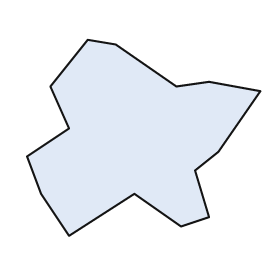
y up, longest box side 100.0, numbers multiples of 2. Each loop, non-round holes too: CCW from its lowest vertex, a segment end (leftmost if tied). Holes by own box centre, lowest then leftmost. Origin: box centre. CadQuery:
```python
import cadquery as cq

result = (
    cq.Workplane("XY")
    .moveTo(-32.0, -42.0)
    .lineTo(-4.0, -24.0)
    .lineTo(16.0, -38.0)
    .lineTo(28.0, -34.0)
    .lineTo(22.0, -14.0)
    .lineTo(32.0, -6.0)
    .lineTo(50.0, 20.0)
    .lineTo(28.0, 24.0)
    .lineTo(14.0, 22.0)
    .lineTo(-12.0, 40.0)
    .lineTo(-24.0, 42.0)
    .lineTo(-40.0, 22.0)
    .lineTo(-32.0, 4.0)
    .lineTo(-50.0, -8.0)
    .lineTo(-44.0, -24.0)
    .close()
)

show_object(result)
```